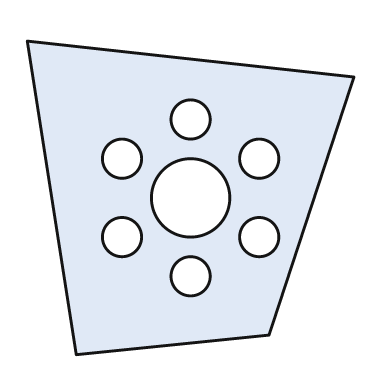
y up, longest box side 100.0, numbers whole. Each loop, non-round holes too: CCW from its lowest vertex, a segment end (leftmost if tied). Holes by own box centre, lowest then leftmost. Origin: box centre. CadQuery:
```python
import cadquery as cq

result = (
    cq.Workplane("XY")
    .moveTo(-35.0, -48.0)
    .lineTo(24.0, -42.0)
    .lineTo(50.0, 37.0)
    .lineTo(-50.0, 48.0)
    .close()
    .moveTo(0.0, -24.0)
    .circle(6.0)
    .moveTo(-21.0, -12.0)
    .circle(6.0)
    .moveTo(21.0, -12.0)
    .circle(6.0)
    .moveTo(0.0, 0.0)
    .circle(12.0)
    .moveTo(-21.0, 12.0)
    .circle(6.0)
    .moveTo(21.0, 12.0)
    .circle(6.0)
    .moveTo(0.0, 24.0)
    .circle(6.0)
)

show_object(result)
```